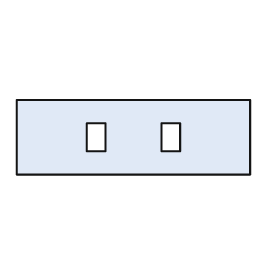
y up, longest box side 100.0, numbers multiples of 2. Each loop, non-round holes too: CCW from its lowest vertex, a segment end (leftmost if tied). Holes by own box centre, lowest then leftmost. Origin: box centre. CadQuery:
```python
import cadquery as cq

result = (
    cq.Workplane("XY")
    .moveTo(-50.0, -16.0)
    .lineTo(50.0, -16.0)
    .lineTo(50.0, 16.0)
    .lineTo(-50.0, 16.0)
    .close()
    .moveTo(-20.0, -6.0)
    .lineTo(-12.0, -6.0)
    .lineTo(-12.0, 6.0)
    .lineTo(-20.0, 6.0)
    .close()
    .moveTo(12.0, -6.0)
    .lineTo(20.0, -6.0)
    .lineTo(20.0, 6.0)
    .lineTo(12.0, 6.0)
    .close()
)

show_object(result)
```